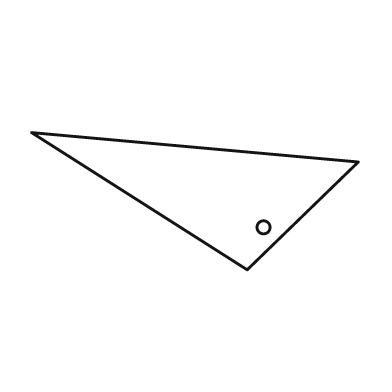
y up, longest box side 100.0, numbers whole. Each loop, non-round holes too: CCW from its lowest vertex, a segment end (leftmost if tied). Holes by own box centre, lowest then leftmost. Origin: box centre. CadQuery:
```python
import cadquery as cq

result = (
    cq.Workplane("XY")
    .moveTo(16.0, -21.0)
    .lineTo(50.0, 12.0)
    .lineTo(-50.0, 21.0)
    .close()
    .moveTo(21.0, -8.0)
    .circle(2.0)
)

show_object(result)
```